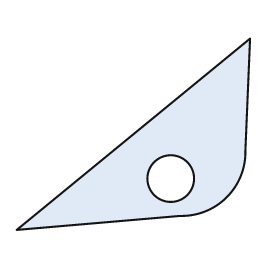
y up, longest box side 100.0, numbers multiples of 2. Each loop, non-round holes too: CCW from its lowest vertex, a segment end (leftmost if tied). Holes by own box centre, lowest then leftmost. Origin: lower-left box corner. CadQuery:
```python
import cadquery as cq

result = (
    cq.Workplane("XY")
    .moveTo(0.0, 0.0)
    .lineTo(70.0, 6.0)
    .threePointArc((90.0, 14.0), (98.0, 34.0))
    .lineTo(100.0, 82.0)
    .close()
    .moveTo(66.0, 22.0)
    .circle(10.0)
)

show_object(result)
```